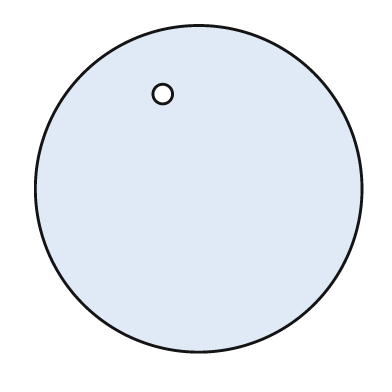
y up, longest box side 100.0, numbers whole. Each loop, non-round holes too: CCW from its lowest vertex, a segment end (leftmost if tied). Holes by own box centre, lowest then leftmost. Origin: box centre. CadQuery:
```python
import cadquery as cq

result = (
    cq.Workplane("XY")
    .moveTo(0.0, 0.0)
    .circle(50.0)
    .moveTo(-11.0, 29.0)
    .circle(3.0)
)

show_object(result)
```